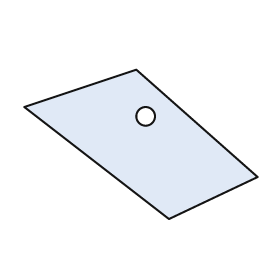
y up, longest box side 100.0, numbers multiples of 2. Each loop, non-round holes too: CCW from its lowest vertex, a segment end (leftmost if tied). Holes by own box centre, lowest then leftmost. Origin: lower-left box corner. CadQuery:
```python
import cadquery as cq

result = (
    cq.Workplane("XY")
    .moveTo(62.0, 0.0)
    .lineTo(100.0, 18.0)
    .lineTo(48.0, 64.0)
    .lineTo(0.0, 48.0)
    .close()
    .moveTo(52.0, 44.0)
    .circle(4.0)
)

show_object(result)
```